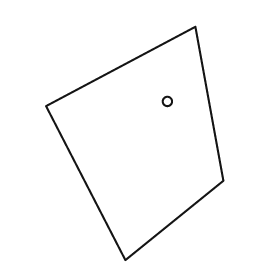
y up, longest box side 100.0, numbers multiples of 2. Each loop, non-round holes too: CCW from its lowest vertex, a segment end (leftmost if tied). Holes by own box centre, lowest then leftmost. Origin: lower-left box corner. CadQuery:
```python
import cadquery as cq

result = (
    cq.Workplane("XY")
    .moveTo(34.0, 0.0)
    .lineTo(76.0, 34.0)
    .lineTo(64.0, 100.0)
    .lineTo(0.0, 66.0)
    .close()
    .moveTo(52.0, 68.0)
    .circle(2.0)
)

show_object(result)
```